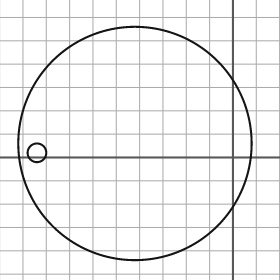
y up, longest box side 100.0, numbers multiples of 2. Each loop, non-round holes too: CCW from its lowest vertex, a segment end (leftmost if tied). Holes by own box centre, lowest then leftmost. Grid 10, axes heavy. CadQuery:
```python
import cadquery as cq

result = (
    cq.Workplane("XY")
    .moveTo(-42.0, 6.0)
    .circle(50.0)
    .moveTo(-84.0, 2.0)
    .circle(4.0)
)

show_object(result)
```